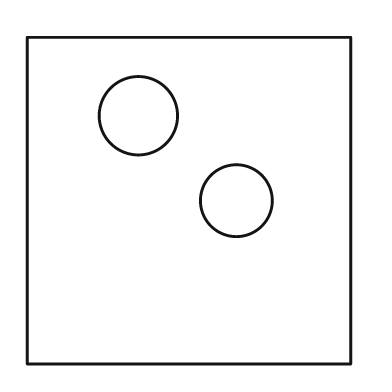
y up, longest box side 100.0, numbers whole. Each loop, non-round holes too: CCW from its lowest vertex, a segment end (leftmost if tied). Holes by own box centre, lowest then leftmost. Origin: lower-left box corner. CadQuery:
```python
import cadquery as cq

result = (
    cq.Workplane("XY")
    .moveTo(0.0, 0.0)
    .lineTo(99.0, 0.0)
    .lineTo(99.0, 100.0)
    .lineTo(0.0, 100.0)
    .close()
    .moveTo(64.0, 50.0)
    .circle(11.0)
    .moveTo(34.0, 76.0)
    .circle(12.0)
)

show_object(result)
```